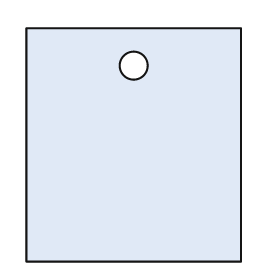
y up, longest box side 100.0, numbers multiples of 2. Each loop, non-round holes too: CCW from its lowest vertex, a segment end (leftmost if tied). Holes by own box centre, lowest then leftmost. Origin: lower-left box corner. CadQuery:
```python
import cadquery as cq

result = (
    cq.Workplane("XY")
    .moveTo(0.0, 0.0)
    .lineTo(92.0, 0.0)
    .lineTo(92.0, 100.0)
    .lineTo(0.0, 100.0)
    .close()
    .moveTo(46.0, 84.0)
    .circle(6.0)
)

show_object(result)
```